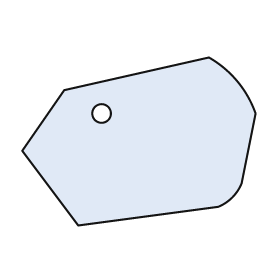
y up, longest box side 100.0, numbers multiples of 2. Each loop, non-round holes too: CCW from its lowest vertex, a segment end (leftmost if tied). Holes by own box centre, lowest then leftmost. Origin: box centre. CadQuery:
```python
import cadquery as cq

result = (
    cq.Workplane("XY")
    .moveTo(-26.0, -36.0)
    .lineTo(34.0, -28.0)
    .threePointArc((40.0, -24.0), (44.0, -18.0))
    .lineTo(50.0, 12.0)
    .threePointArc((42.0, 26.0), (30.0, 36.0))
    .lineTo(-32.0, 22.0)
    .lineTo(-50.0, -4.0)
    .close()
    .moveTo(-16.0, 12.0)
    .circle(4.0)
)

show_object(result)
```